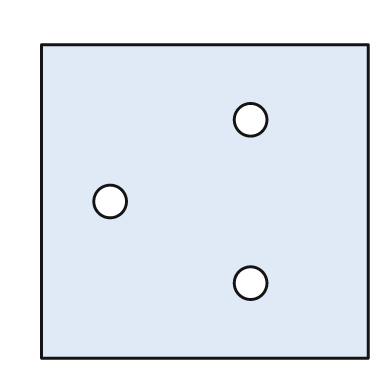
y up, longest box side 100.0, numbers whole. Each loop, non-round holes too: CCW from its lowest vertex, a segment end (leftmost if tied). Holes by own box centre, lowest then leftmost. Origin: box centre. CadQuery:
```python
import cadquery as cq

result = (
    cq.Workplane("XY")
    .moveTo(-50.0, -48.0)
    .lineTo(50.0, -48.0)
    .lineTo(50.0, 48.0)
    .lineTo(-50.0, 48.0)
    .close()
    .moveTo(14.0, -25.0)
    .circle(5.0)
    .moveTo(-29.0, 0.0)
    .circle(5.0)
    .moveTo(14.0, 25.0)
    .circle(5.0)
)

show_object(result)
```